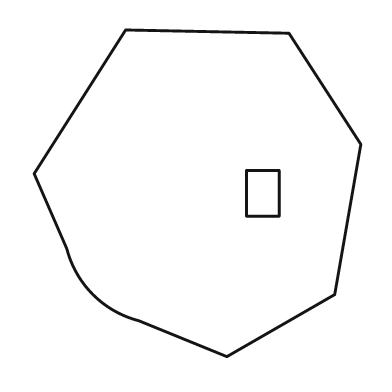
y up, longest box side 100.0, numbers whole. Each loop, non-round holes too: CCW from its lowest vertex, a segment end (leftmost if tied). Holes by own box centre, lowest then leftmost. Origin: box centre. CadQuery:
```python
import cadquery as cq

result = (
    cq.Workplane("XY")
    .moveTo(9.0, -50.0)
    .lineTo(42.0, -31.0)
    .lineTo(50.0, 15.0)
    .lineTo(28.0, 49.0)
    .lineTo(-22.0, 50.0)
    .lineTo(-50.0, 6.0)
    .lineTo(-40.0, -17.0)
    .threePointArc((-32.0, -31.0), (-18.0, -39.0))
    .close()
    .moveTo(15.0, -7.0)
    .lineTo(25.0, -7.0)
    .lineTo(25.0, 7.0)
    .lineTo(15.0, 7.0)
    .close()
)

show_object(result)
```